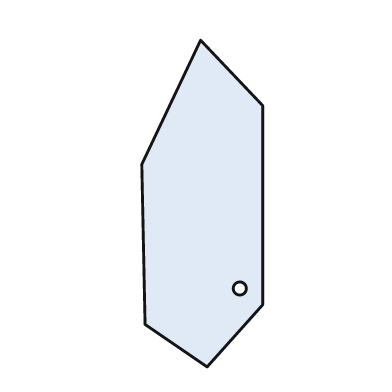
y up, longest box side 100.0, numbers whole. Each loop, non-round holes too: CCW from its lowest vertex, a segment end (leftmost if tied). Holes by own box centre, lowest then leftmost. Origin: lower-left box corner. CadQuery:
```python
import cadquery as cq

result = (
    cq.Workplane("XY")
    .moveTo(20.0, 0.0)
    .lineTo(37.0, 19.0)
    .lineTo(37.0, 80.0)
    .lineTo(18.0, 100.0)
    .lineTo(0.0, 62.0)
    .lineTo(1.0, 13.0)
    .close()
    .moveTo(30.0, 24.0)
    .circle(2.0)
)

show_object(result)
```